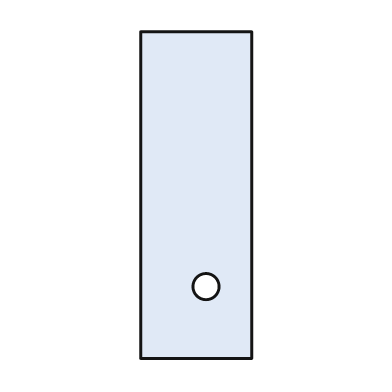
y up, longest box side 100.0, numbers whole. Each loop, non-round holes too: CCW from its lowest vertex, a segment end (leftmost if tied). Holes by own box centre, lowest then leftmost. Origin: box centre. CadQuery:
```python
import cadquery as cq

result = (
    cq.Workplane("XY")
    .moveTo(-17.0, -50.0)
    .lineTo(17.0, -50.0)
    .lineTo(17.0, 50.0)
    .lineTo(-17.0, 50.0)
    .close()
    .moveTo(3.0, -28.0)
    .circle(4.0)
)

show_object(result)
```